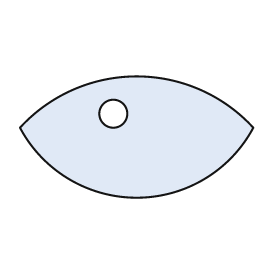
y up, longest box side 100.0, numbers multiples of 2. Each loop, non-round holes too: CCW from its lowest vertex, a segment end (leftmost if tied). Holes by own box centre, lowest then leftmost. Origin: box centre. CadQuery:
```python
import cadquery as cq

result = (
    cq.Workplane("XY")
    .moveTo(-50.0, 4.0)
    .threePointArc((0.0, -26.0), (50.0, 4.0))
    .threePointArc((0.0, 26.0), (-50.0, 4.0))
    .close()
    .moveTo(-10.0, 10.0)
    .circle(6.0)
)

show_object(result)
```